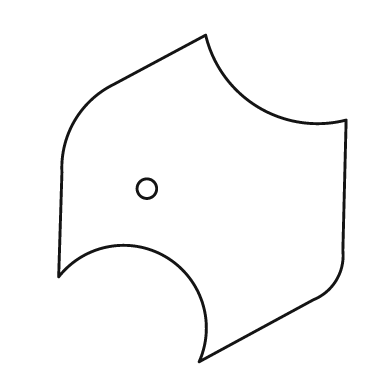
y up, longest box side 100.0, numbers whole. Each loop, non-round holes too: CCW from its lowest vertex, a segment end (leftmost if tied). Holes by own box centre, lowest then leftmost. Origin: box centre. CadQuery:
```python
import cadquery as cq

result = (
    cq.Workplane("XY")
    .moveTo(-1.0, -50.0)
    .lineTo(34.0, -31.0)
    .threePointArc((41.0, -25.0), (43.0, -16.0))
    .lineTo(44.0, 24.0)
    .threePointArc((17.0, 28.0), (1.0, 50.0))
    .lineTo(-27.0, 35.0)
    .threePointArc((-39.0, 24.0), (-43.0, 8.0))
    .lineTo(-44.0, -24.0)
    .threePointArc((-11.0, -18.0), (-1.0, -50.0))
    .close()
    .moveTo(-17.0, 3.0)
    .circle(3.0)
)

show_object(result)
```